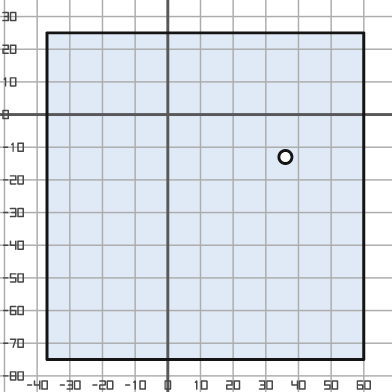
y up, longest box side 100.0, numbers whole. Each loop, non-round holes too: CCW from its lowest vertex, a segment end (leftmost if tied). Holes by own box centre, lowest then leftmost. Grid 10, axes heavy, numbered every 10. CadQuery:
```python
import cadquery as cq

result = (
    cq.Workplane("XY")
    .moveTo(-37.0, -75.0)
    .lineTo(60.0, -75.0)
    .lineTo(60.0, 25.0)
    .lineTo(-37.0, 25.0)
    .close()
    .moveTo(36.0, -13.0)
    .circle(2.0)
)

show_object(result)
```